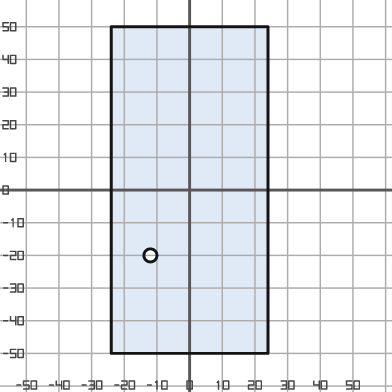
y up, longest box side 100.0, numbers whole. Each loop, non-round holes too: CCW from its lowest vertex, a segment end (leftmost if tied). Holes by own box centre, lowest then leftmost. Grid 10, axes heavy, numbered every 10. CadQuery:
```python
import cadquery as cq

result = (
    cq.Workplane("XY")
    .moveTo(-24.0, -50.0)
    .lineTo(24.0, -50.0)
    .lineTo(24.0, 50.0)
    .lineTo(-24.0, 50.0)
    .close()
    .moveTo(-12.0, -20.0)
    .circle(2.0)
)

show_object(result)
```